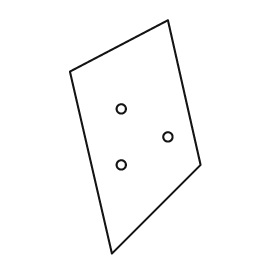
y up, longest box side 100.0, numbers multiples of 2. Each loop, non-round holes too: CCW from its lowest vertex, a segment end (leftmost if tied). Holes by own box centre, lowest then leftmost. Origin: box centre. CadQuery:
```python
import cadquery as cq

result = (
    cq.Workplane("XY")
    .moveTo(-10.0, -50.0)
    .lineTo(28.0, -12.0)
    .lineTo(14.0, 50.0)
    .lineTo(-28.0, 28.0)
    .close()
    .moveTo(-6.0, -12.0)
    .circle(2.0)
    .moveTo(14.0, 0.0)
    .circle(2.0)
    .moveTo(-6.0, 12.0)
    .circle(2.0)
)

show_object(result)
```